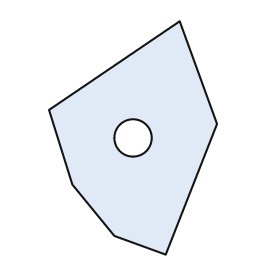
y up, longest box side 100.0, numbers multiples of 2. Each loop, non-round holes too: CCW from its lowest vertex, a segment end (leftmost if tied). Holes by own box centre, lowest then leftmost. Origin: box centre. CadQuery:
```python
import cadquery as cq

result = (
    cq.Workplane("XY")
    .moveTo(14.0, -50.0)
    .lineTo(36.0, 6.0)
    .lineTo(20.0, 50.0)
    .lineTo(-36.0, 12.0)
    .lineTo(-26.0, -20.0)
    .lineTo(-8.0, -42.0)
    .close()
    .moveTo(0.0, 0.0)
    .circle(8.0)
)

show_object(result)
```